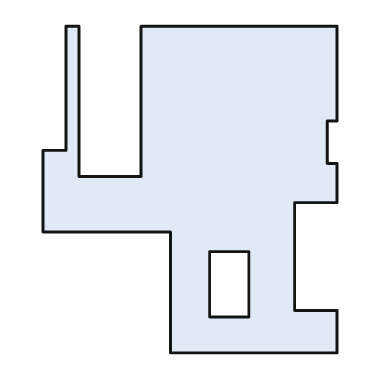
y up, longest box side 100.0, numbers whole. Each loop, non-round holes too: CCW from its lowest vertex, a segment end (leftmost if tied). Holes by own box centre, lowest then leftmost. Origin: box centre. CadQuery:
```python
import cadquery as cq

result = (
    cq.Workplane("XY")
    .moveTo(-6.0, -50.0)
    .lineTo(45.0, -50.0)
    .lineTo(45.0, -37.0)
    .lineTo(32.0, -37.0)
    .lineTo(32.0, -4.0)
    .lineTo(45.0, -4.0)
    .lineTo(45.0, 8.0)
    .lineTo(42.0, 8.0)
    .lineTo(42.0, 21.0)
    .lineTo(45.0, 21.0)
    .lineTo(45.0, 50.0)
    .lineTo(-15.0, 50.0)
    .lineTo(-15.0, 4.0)
    .lineTo(-34.0, 4.0)
    .lineTo(-34.0, 50.0)
    .lineTo(-38.0, 50.0)
    .lineTo(-38.0, 12.0)
    .lineTo(-45.0, 12.0)
    .lineTo(-45.0, -13.0)
    .lineTo(-6.0, -13.0)
    .close()
    .moveTo(6.0, -39.0)
    .lineTo(18.0, -39.0)
    .lineTo(18.0, -19.0)
    .lineTo(6.0, -19.0)
    .close()
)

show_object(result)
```